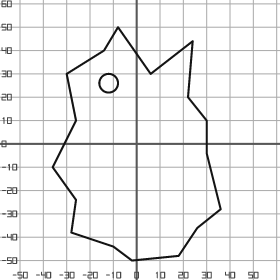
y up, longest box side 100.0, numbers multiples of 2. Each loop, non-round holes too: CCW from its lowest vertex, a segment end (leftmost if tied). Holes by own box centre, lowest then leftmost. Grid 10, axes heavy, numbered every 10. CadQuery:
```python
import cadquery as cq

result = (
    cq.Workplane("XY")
    .moveTo(-2.0, -50.0)
    .lineTo(18.0, -48.0)
    .lineTo(26.0, -36.0)
    .lineTo(36.0, -28.0)
    .lineTo(30.0, -4.0)
    .lineTo(30.0, 10.0)
    .lineTo(22.0, 20.0)
    .lineTo(24.0, 44.0)
    .lineTo(6.0, 30.0)
    .lineTo(-8.0, 50.0)
    .lineTo(-14.0, 40.0)
    .lineTo(-30.0, 30.0)
    .lineTo(-26.0, 10.0)
    .lineTo(-36.0, -10.0)
    .lineTo(-26.0, -24.0)
    .lineTo(-28.0, -38.0)
    .lineTo(-10.0, -44.0)
    .close()
    .moveTo(-12.0, 26.0)
    .circle(4.0)
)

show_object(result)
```